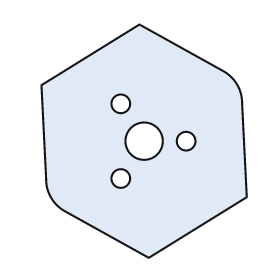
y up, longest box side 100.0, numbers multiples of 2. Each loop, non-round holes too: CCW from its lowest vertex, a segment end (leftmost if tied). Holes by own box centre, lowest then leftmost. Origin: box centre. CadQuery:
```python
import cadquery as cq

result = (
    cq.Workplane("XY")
    .moveTo(2.0, -50.0)
    .lineTo(44.0, -24.0)
    .lineTo(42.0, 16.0)
    .threePointArc((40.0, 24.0), (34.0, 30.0))
    .lineTo(-2.0, 50.0)
    .lineTo(-44.0, 24.0)
    .lineTo(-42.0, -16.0)
    .threePointArc((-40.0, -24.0), (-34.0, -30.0))
    .close()
    .moveTo(-10.0, -16.0)
    .circle(4.0)
    .moveTo(0.0, 0.0)
    .circle(8.0)
    .moveTo(18.0, 0.0)
    .circle(4.0)
    .moveTo(-10.0, 16.0)
    .circle(4.0)
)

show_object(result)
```